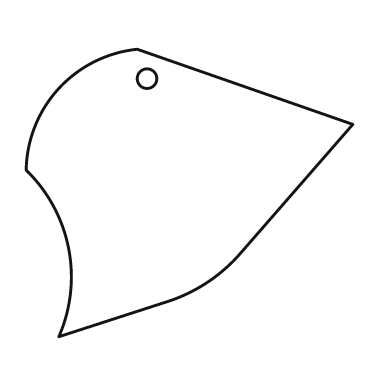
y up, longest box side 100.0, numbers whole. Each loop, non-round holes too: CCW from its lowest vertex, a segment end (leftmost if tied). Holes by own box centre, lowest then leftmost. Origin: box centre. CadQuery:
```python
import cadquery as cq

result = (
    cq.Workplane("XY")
    .moveTo(-40.0, -44.0)
    .lineTo(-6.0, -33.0)
    .threePointArc((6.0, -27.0), (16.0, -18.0))
    .lineTo(50.0, 21.0)
    .lineTo(-16.0, 44.0)
    .threePointArc((-40.0, 32.0), (-50.0, 7.0))
    .threePointArc((-37.0, -17.0), (-40.0, -44.0))
    .close()
    .moveTo(-13.0, 35.0)
    .circle(3.0)
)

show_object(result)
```